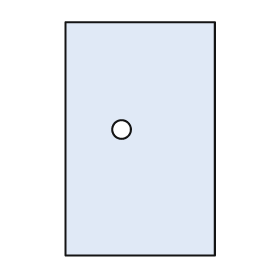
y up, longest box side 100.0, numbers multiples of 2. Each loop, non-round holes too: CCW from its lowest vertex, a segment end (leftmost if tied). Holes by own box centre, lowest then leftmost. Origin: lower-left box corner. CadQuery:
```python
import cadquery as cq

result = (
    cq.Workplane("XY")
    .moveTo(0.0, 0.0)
    .lineTo(64.0, 0.0)
    .lineTo(64.0, 100.0)
    .lineTo(0.0, 100.0)
    .close()
    .moveTo(24.0, 54.0)
    .circle(4.0)
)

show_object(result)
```